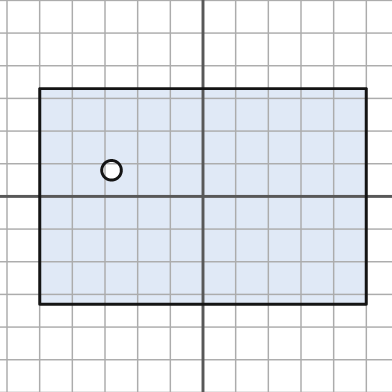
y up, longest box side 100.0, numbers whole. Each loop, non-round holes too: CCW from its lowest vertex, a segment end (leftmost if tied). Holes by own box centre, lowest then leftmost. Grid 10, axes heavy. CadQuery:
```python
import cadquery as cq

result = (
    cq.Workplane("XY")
    .moveTo(-50.0, -33.0)
    .lineTo(50.0, -33.0)
    .lineTo(50.0, 33.0)
    .lineTo(-50.0, 33.0)
    .close()
    .moveTo(-28.0, 8.0)
    .circle(3.0)
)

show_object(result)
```